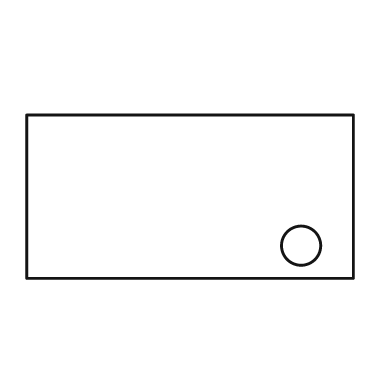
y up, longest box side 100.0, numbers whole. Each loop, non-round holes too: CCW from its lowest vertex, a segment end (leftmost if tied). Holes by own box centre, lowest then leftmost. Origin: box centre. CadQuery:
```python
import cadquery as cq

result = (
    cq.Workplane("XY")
    .moveTo(-50.0, -25.0)
    .lineTo(50.0, -25.0)
    .lineTo(50.0, 25.0)
    .lineTo(-50.0, 25.0)
    .close()
    .moveTo(34.0, -15.0)
    .circle(6.0)
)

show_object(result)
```